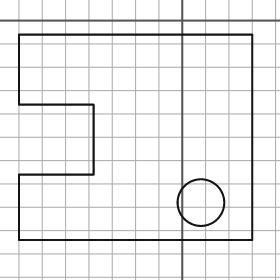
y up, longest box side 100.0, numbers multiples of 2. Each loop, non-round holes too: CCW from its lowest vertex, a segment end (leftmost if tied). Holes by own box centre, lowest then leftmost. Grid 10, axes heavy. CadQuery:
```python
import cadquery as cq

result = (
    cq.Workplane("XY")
    .moveTo(-70.0, -94.0)
    .lineTo(30.0, -94.0)
    .lineTo(30.0, -6.0)
    .lineTo(-70.0, -6.0)
    .lineTo(-70.0, -36.0)
    .lineTo(-38.0, -36.0)
    .lineTo(-38.0, -66.0)
    .lineTo(-70.0, -66.0)
    .close()
    .moveTo(8.0, -78.0)
    .circle(10.0)
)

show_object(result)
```